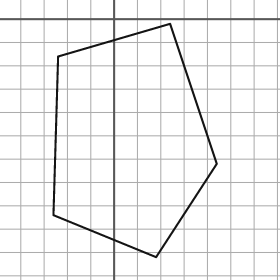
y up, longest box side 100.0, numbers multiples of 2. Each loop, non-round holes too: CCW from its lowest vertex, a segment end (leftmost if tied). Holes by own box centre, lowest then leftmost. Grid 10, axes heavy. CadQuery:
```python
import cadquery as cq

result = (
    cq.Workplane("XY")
    .moveTo(18.0, -102.0)
    .lineTo(44.0, -62.0)
    .lineTo(24.0, -2.0)
    .lineTo(-24.0, -16.0)
    .lineTo(-26.0, -84.0)
    .close()
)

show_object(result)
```